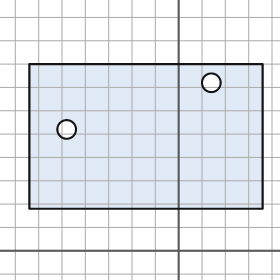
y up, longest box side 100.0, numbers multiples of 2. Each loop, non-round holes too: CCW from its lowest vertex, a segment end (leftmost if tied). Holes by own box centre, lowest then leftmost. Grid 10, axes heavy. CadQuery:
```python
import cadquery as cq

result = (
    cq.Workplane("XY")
    .moveTo(-64.0, 18.0)
    .lineTo(36.0, 18.0)
    .lineTo(36.0, 80.0)
    .lineTo(-64.0, 80.0)
    .close()
    .moveTo(-48.0, 52.0)
    .circle(4.0)
    .moveTo(14.0, 72.0)
    .circle(4.0)
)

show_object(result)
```